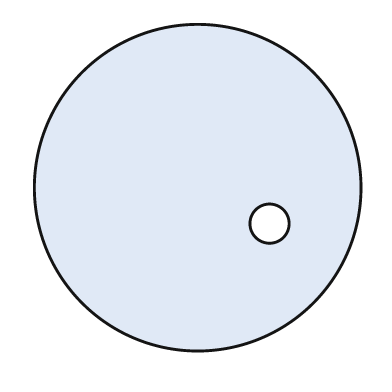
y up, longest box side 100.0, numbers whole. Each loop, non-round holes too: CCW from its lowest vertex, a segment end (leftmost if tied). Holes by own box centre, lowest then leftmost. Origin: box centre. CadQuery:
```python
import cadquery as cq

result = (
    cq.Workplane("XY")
    .moveTo(0.0, 0.0)
    .circle(50.0)
    .moveTo(22.0, -11.0)
    .circle(6.0)
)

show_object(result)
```